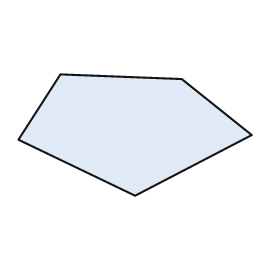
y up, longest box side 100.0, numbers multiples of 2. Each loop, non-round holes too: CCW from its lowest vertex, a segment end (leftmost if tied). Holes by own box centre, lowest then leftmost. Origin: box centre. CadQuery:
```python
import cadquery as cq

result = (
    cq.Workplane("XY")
    .moveTo(0.0, -26.0)
    .lineTo(50.0, 0.0)
    .lineTo(20.0, 24.0)
    .lineTo(-32.0, 26.0)
    .lineTo(-50.0, -2.0)
    .close()
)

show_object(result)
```